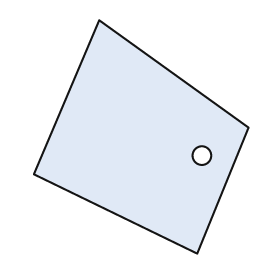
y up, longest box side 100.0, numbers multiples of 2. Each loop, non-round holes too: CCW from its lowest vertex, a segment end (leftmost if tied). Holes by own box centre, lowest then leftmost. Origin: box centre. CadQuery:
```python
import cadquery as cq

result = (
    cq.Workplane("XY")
    .moveTo(24.0, -50.0)
    .lineTo(46.0, 4.0)
    .lineTo(-18.0, 50.0)
    .lineTo(-46.0, -16.0)
    .close()
    .moveTo(26.0, -8.0)
    .circle(4.0)
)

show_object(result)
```